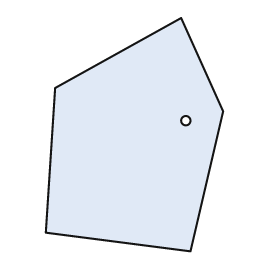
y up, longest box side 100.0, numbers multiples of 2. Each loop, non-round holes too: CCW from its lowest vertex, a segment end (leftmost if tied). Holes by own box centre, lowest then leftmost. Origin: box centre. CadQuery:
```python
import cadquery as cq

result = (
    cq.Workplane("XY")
    .moveTo(24.0, -50.0)
    .lineTo(38.0, 10.0)
    .lineTo(20.0, 50.0)
    .lineTo(-34.0, 20.0)
    .lineTo(-38.0, -42.0)
    .close()
    .moveTo(22.0, 6.0)
    .circle(2.0)
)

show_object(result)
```